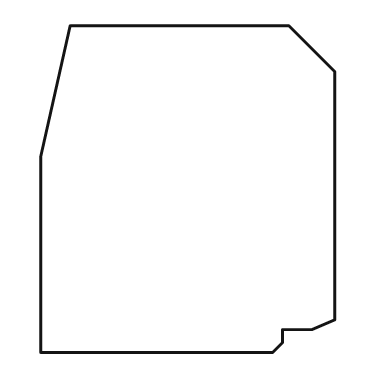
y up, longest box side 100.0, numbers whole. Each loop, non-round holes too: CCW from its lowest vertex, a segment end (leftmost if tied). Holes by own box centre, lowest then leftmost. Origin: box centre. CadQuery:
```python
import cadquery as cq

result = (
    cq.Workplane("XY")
    .moveTo(-45.0, -50.0)
    .lineTo(26.0, -50.0)
    .lineTo(29.0, -47.0)
    .lineTo(29.0, -43.0)
    .lineTo(38.0, -43.0)
    .lineTo(45.0, -40.0)
    .lineTo(45.0, 36.0)
    .lineTo(31.0, 50.0)
    .lineTo(-36.0, 50.0)
    .lineTo(-45.0, 10.0)
    .close()
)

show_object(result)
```